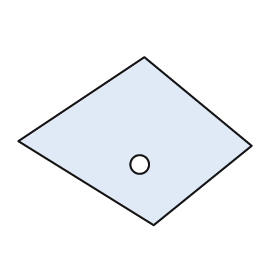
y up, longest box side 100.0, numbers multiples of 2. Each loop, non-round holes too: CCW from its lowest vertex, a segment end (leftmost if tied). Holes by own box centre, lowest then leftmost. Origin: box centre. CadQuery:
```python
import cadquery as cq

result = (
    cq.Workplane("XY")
    .moveTo(8.0, -36.0)
    .lineTo(50.0, -2.0)
    .lineTo(4.0, 36.0)
    .lineTo(-50.0, 0.0)
    .close()
    .moveTo(2.0, -10.0)
    .circle(4.0)
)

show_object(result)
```